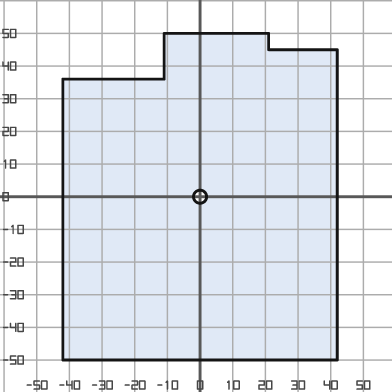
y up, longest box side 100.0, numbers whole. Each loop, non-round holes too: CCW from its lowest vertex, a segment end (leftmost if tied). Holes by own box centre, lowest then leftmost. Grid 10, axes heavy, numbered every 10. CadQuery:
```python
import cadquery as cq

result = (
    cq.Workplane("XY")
    .moveTo(-42.0, -50.0)
    .lineTo(42.0, -50.0)
    .lineTo(42.0, 45.0)
    .lineTo(21.0, 45.0)
    .lineTo(21.0, 50.0)
    .lineTo(-11.0, 50.0)
    .lineTo(-11.0, 36.0)
    .lineTo(-42.0, 36.0)
    .close()
    .moveTo(0.0, 0.0)
    .circle(2.0)
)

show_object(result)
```